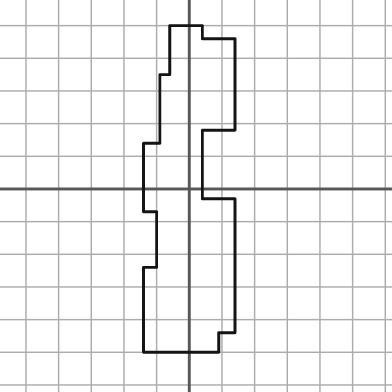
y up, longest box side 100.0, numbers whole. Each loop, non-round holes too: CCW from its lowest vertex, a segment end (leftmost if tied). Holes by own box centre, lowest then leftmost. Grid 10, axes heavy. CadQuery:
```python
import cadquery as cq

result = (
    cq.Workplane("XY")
    .moveTo(-14.0, -50.0)
    .lineTo(9.0, -50.0)
    .lineTo(9.0, -44.0)
    .lineTo(14.0, -44.0)
    .lineTo(14.0, -3.0)
    .lineTo(4.0, -3.0)
    .lineTo(4.0, 18.0)
    .lineTo(14.0, 18.0)
    .lineTo(14.0, 46.0)
    .lineTo(4.0, 46.0)
    .lineTo(4.0, 50.0)
    .lineTo(-6.0, 50.0)
    .lineTo(-6.0, 35.0)
    .lineTo(-9.0, 35.0)
    .lineTo(-9.0, 14.0)
    .lineTo(-14.0, 14.0)
    .lineTo(-14.0, -7.0)
    .lineTo(-10.0, -7.0)
    .lineTo(-10.0, -24.0)
    .lineTo(-14.0, -24.0)
    .close()
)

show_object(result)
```